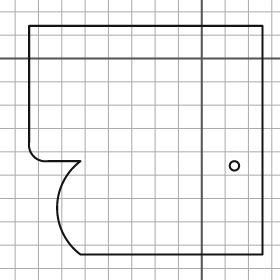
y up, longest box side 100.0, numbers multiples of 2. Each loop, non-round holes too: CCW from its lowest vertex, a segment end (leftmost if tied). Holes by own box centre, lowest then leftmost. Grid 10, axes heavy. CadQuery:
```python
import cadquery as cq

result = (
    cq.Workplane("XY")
    .moveTo(-52.0, -84.0)
    .lineTo(26.0, -84.0)
    .lineTo(26.0, 14.0)
    .lineTo(-74.0, 14.0)
    .lineTo(-74.0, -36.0)
    .threePointArc((-72.0, -42.0), (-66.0, -44.0))
    .lineTo(-52.0, -44.0)
    .threePointArc((-62.0, -64.0), (-52.0, -84.0))
    .close()
    .moveTo(14.0, -46.0)
    .circle(2.0)
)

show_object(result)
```